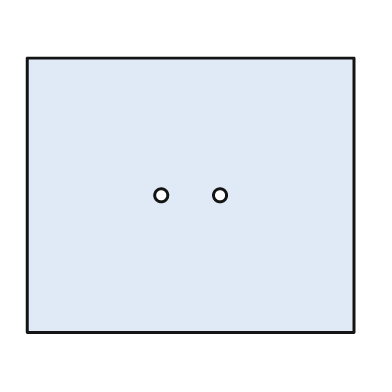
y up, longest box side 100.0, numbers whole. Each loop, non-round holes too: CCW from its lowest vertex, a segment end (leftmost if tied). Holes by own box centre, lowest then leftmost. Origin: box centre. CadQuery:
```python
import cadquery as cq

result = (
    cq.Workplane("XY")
    .moveTo(-50.0, -42.0)
    .lineTo(50.0, -42.0)
    .lineTo(50.0, 42.0)
    .lineTo(-50.0, 42.0)
    .close()
    .moveTo(-9.0, 0.0)
    .circle(2.0)
    .moveTo(9.0, 0.0)
    .circle(2.0)
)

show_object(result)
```